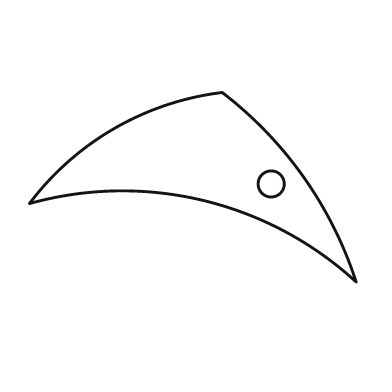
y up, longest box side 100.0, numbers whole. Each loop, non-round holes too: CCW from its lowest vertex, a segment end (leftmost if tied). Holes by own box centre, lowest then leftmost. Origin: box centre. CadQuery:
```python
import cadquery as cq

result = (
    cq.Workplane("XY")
    .moveTo(50.0, -29.0)
    .threePointArc((34.0, 3.0), (9.0, 29.0))
    .threePointArc((-24.0, 18.0), (-50.0, -5.0))
    .threePointArc((3.0, -4.0), (50.0, -29.0))
    .close()
    .moveTo(24.0, 1.0)
    .circle(4.0)
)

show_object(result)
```